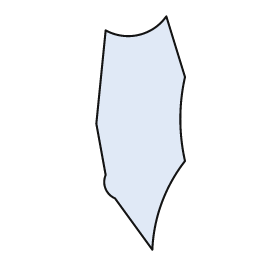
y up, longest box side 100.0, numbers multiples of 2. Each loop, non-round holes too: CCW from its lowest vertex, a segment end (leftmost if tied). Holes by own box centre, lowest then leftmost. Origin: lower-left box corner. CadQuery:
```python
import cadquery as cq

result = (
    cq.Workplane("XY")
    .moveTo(24.0, 0.0)
    .threePointArc((28.0, 20.0), (38.0, 38.0))
    .threePointArc((36.0, 56.0), (38.0, 74.0))
    .lineTo(30.0, 100.0)
    .threePointArc((18.0, 92.0), (4.0, 94.0))
    .lineTo(0.0, 54.0)
    .lineTo(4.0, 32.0)
    .threePointArc((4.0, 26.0), (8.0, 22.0))
    .close()
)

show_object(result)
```